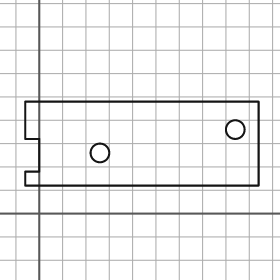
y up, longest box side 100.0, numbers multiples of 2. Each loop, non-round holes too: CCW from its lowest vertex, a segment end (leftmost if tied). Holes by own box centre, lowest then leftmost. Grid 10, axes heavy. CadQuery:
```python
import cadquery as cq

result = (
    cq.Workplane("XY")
    .moveTo(-6.0, 12.0)
    .lineTo(94.0, 12.0)
    .lineTo(94.0, 48.0)
    .lineTo(-6.0, 48.0)
    .lineTo(-6.0, 32.0)
    .lineTo(0.0, 32.0)
    .lineTo(0.0, 18.0)
    .lineTo(-6.0, 18.0)
    .close()
    .moveTo(26.0, 26.0)
    .circle(4.0)
    .moveTo(84.0, 36.0)
    .circle(4.0)
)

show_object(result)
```